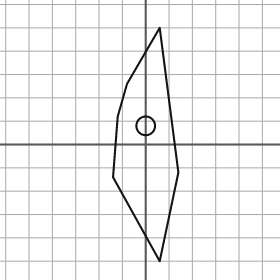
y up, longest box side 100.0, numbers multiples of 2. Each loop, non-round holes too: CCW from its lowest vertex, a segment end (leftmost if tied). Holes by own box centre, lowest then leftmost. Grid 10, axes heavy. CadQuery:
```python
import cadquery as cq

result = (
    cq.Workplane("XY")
    .moveTo(6.0, -50.0)
    .lineTo(14.0, -12.0)
    .lineTo(6.0, 50.0)
    .lineTo(-8.0, 26.0)
    .lineTo(-12.0, 12.0)
    .lineTo(-14.0, -14.0)
    .close()
    .moveTo(0.0, 8.0)
    .circle(4.0)
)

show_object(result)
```